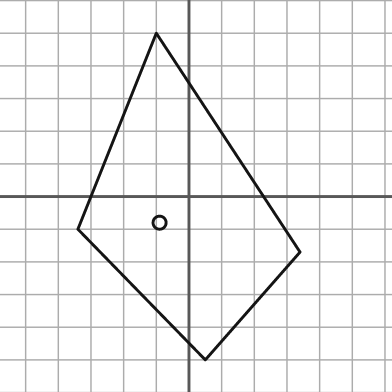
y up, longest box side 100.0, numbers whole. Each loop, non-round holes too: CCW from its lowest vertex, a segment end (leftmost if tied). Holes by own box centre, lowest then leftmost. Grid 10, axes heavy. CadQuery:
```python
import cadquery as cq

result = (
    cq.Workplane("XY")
    .moveTo(5.0, -50.0)
    .lineTo(34.0, -17.0)
    .lineTo(-10.0, 50.0)
    .lineTo(-34.0, -10.0)
    .close()
    .moveTo(-9.0, -8.0)
    .circle(2.0)
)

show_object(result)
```